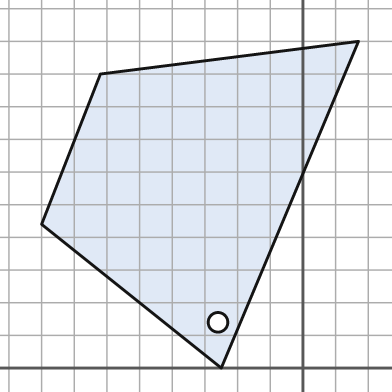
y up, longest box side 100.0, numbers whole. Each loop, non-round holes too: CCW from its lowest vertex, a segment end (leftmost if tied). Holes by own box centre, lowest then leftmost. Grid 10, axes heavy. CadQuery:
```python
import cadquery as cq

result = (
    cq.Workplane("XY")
    .moveTo(-25.0, 0.0)
    .lineTo(17.0, 100.0)
    .lineTo(-62.0, 90.0)
    .lineTo(-80.0, 44.0)
    .close()
    .moveTo(-26.0, 14.0)
    .circle(3.0)
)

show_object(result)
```